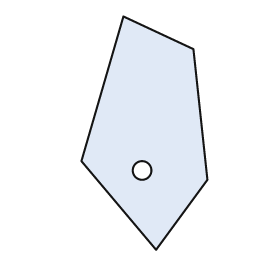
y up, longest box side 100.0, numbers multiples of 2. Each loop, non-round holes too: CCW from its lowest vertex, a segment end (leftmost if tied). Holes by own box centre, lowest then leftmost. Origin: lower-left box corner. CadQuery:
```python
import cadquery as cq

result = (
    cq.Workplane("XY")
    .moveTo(32.0, 0.0)
    .lineTo(54.0, 30.0)
    .lineTo(48.0, 86.0)
    .lineTo(18.0, 100.0)
    .lineTo(0.0, 38.0)
    .close()
    .moveTo(26.0, 34.0)
    .circle(4.0)
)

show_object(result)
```